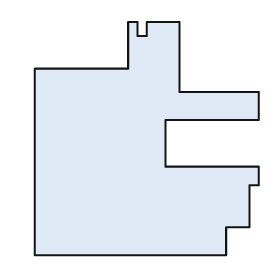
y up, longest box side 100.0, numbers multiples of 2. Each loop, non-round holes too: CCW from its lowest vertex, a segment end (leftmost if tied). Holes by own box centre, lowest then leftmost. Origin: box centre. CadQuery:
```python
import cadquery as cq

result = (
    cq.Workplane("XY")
    .moveTo(-48.0, -50.0)
    .lineTo(34.0, -50.0)
    .lineTo(34.0, -38.0)
    .lineTo(44.0, -38.0)
    .lineTo(44.0, -20.0)
    .lineTo(48.0, -20.0)
    .lineTo(48.0, -12.0)
    .lineTo(8.0, -12.0)
    .lineTo(8.0, 8.0)
    .lineTo(48.0, 8.0)
    .lineTo(48.0, 20.0)
    .lineTo(14.0, 20.0)
    .lineTo(14.0, 50.0)
    .lineTo(0.0, 50.0)
    .lineTo(0.0, 44.0)
    .lineTo(-4.0, 44.0)
    .lineTo(-4.0, 50.0)
    .lineTo(-8.0, 50.0)
    .lineTo(-8.0, 30.0)
    .lineTo(-48.0, 30.0)
    .close()
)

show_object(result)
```